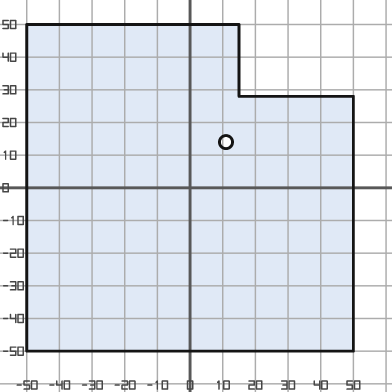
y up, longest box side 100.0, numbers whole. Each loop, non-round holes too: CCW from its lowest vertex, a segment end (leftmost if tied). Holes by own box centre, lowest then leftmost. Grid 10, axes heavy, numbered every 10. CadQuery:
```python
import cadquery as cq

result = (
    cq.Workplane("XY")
    .moveTo(-50.0, -50.0)
    .lineTo(50.0, -50.0)
    .lineTo(50.0, 28.0)
    .lineTo(15.0, 28.0)
    .lineTo(15.0, 50.0)
    .lineTo(-50.0, 50.0)
    .close()
    .moveTo(11.0, 14.0)
    .circle(2.0)
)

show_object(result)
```